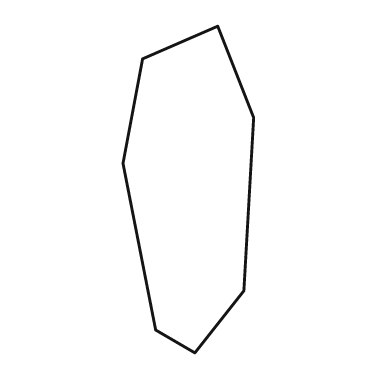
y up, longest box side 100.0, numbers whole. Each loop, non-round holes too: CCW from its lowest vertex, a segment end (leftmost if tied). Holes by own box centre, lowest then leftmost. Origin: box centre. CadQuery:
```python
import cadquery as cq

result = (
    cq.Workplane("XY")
    .moveTo(2.0, -50.0)
    .lineTo(17.0, -31.0)
    .lineTo(20.0, 22.0)
    .lineTo(9.0, 50.0)
    .lineTo(-14.0, 40.0)
    .lineTo(-20.0, 8.0)
    .lineTo(-10.0, -43.0)
    .close()
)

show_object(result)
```